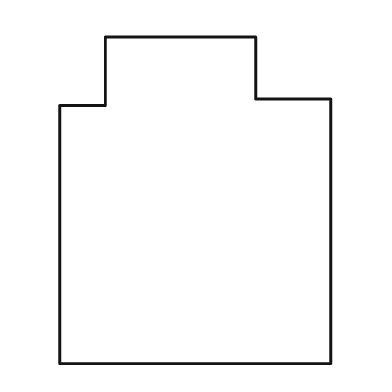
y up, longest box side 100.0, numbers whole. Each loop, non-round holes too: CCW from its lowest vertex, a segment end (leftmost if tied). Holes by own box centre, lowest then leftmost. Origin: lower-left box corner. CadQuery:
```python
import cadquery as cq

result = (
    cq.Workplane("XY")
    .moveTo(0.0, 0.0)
    .lineTo(83.0, 0.0)
    .lineTo(83.0, 81.0)
    .lineTo(60.0, 81.0)
    .lineTo(60.0, 100.0)
    .lineTo(14.0, 100.0)
    .lineTo(14.0, 79.0)
    .lineTo(0.0, 79.0)
    .close()
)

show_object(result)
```